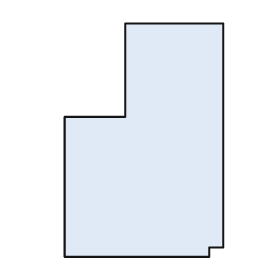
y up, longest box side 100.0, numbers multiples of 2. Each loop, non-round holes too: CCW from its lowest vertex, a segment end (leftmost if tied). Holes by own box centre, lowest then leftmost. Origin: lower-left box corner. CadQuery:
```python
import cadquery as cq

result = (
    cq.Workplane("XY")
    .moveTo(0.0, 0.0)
    .lineTo(62.0, 0.0)
    .lineTo(62.0, 4.0)
    .lineTo(68.0, 4.0)
    .lineTo(68.0, 100.0)
    .lineTo(26.0, 100.0)
    .lineTo(26.0, 60.0)
    .lineTo(0.0, 60.0)
    .close()
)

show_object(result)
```